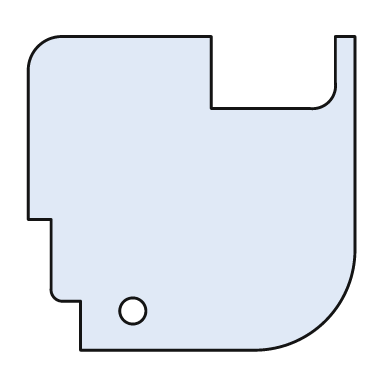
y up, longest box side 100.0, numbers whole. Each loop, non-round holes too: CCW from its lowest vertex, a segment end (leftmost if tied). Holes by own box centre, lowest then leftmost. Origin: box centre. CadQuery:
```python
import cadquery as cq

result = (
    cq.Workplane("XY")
    .moveTo(-34.0, -48.0)
    .lineTo(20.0, -48.0)
    .threePointArc((41.0, -39.0), (50.0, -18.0))
    .lineTo(50.0, 48.0)
    .lineTo(44.0, 48.0)
    .lineTo(44.0, 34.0)
    .threePointArc((42.0, 28.0), (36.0, 26.0))
    .lineTo(6.0, 26.0)
    .lineTo(6.0, 48.0)
    .lineTo(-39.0, 48.0)
    .threePointArc((-47.0, 45.0), (-50.0, 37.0))
    .lineTo(-50.0, -8.0)
    .lineTo(-43.0, -8.0)
    .lineTo(-43.0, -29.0)
    .threePointArc((-42.0, -32.0), (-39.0, -33.0))
    .lineTo(-34.0, -33.0)
    .close()
    .moveTo(-18.0, -36.0)
    .circle(4.0)
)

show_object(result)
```